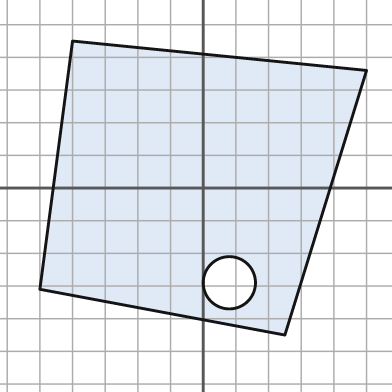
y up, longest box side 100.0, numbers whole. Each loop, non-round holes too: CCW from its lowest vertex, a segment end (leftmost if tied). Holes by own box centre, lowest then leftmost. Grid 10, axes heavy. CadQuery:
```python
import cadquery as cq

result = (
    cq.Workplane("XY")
    .moveTo(25.0, -45.0)
    .lineTo(50.0, 36.0)
    .lineTo(-40.0, 45.0)
    .lineTo(-50.0, -31.0)
    .close()
    .moveTo(8.0, -29.0)
    .circle(8.0)
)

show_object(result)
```